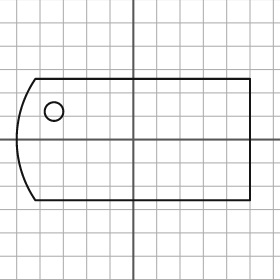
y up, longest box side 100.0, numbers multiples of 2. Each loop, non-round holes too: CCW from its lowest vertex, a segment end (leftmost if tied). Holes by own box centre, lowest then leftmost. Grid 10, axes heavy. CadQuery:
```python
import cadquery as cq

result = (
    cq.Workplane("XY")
    .moveTo(-42.0, -26.0)
    .lineTo(50.0, -26.0)
    .lineTo(50.0, 26.0)
    .lineTo(-42.0, 26.0)
    .threePointArc((-50.0, 0.0), (-42.0, -26.0))
    .close()
    .moveTo(-34.0, 12.0)
    .circle(4.0)
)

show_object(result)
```